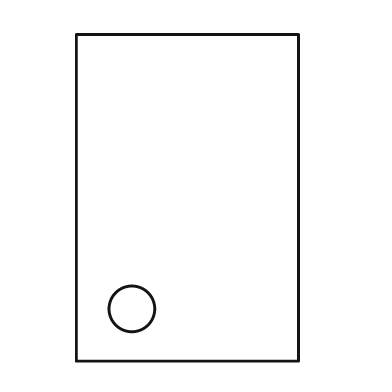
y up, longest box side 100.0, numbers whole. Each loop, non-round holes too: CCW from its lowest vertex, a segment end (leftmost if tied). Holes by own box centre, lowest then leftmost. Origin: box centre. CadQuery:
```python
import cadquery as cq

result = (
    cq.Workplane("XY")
    .moveTo(-34.0, -50.0)
    .lineTo(34.0, -50.0)
    .lineTo(34.0, 50.0)
    .lineTo(-34.0, 50.0)
    .close()
    .moveTo(-17.0, -34.0)
    .circle(7.0)
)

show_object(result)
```